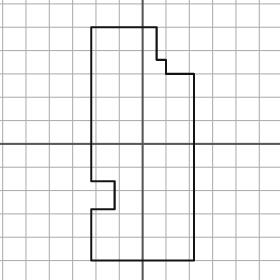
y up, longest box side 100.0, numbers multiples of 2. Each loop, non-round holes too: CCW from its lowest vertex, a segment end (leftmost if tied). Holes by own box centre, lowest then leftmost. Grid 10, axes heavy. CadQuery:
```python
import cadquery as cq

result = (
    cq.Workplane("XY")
    .moveTo(-22.0, -50.0)
    .lineTo(22.0, -50.0)
    .lineTo(22.0, 30.0)
    .lineTo(10.0, 30.0)
    .lineTo(10.0, 36.0)
    .lineTo(6.0, 36.0)
    .lineTo(6.0, 50.0)
    .lineTo(-22.0, 50.0)
    .lineTo(-22.0, -16.0)
    .lineTo(-12.0, -16.0)
    .lineTo(-12.0, -28.0)
    .lineTo(-22.0, -28.0)
    .close()
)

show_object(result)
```